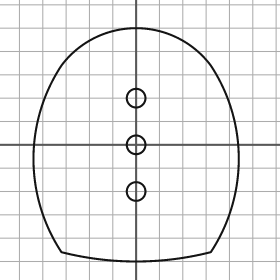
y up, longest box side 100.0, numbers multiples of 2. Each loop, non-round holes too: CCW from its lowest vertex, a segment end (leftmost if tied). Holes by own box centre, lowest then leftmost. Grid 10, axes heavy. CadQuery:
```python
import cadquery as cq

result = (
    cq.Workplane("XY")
    .moveTo(-32.0, -46.0)
    .threePointArc((0.0, -50.0), (32.0, -46.0))
    .threePointArc((44.0, -6.0), (32.0, 34.0))
    .threePointArc((0.0, 50.0), (-32.0, 34.0))
    .threePointArc((-44.0, -6.0), (-32.0, -46.0))
    .close()
    .moveTo(0.0, -20.0)
    .circle(4.0)
    .moveTo(0.0, 0.0)
    .circle(4.0)
    .moveTo(0.0, 20.0)
    .circle(4.0)
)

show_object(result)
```